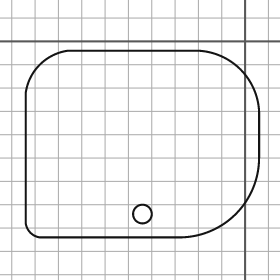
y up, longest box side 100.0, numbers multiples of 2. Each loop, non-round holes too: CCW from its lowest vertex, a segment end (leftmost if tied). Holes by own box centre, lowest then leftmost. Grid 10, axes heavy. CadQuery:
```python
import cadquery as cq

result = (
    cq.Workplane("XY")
    .moveTo(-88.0, -84.0)
    .lineTo(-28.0, -84.0)
    .threePointArc((-4.0, -74.0), (6.0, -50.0))
    .lineTo(6.0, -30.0)
    .threePointArc((-2.0, -12.0), (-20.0, -4.0))
    .lineTo(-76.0, -4.0)
    .threePointArc((-88.0, -10.0), (-94.0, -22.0))
    .lineTo(-94.0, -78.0)
    .threePointArc((-92.0, -82.0), (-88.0, -84.0))
    .close()
    .moveTo(-44.0, -74.0)
    .circle(4.0)
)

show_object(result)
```